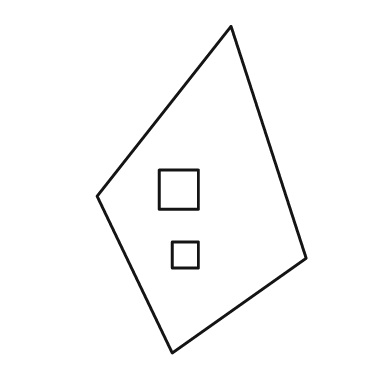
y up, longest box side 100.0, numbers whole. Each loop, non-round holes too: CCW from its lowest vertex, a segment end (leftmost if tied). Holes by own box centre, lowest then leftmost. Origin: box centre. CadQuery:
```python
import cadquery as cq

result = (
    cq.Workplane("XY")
    .moveTo(-9.0, -50.0)
    .lineTo(32.0, -21.0)
    .lineTo(9.0, 50.0)
    .lineTo(-32.0, -2.0)
    .close()
    .moveTo(-9.0, -24.0)
    .lineTo(-1.0, -24.0)
    .lineTo(-1.0, -16.0)
    .lineTo(-9.0, -16.0)
    .close()
    .moveTo(-13.0, -6.0)
    .lineTo(-1.0, -6.0)
    .lineTo(-1.0, 6.0)
    .lineTo(-13.0, 6.0)
    .close()
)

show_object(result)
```